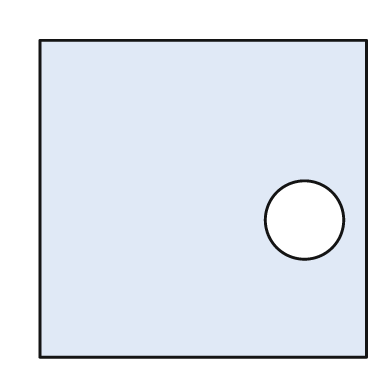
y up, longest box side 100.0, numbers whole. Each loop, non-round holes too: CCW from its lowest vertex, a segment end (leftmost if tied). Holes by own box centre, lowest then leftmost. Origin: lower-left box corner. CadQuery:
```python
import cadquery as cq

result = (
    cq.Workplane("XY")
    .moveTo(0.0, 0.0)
    .lineTo(100.0, 0.0)
    .lineTo(100.0, 97.0)
    .lineTo(0.0, 97.0)
    .close()
    .moveTo(81.0, 42.0)
    .circle(12.0)
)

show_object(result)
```